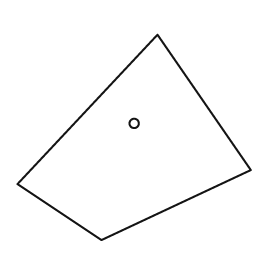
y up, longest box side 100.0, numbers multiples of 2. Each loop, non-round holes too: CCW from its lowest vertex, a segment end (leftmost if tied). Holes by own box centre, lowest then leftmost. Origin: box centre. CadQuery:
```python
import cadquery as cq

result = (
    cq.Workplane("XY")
    .moveTo(-14.0, -44.0)
    .lineTo(50.0, -14.0)
    .lineTo(10.0, 44.0)
    .lineTo(-50.0, -20.0)
    .close()
    .moveTo(0.0, 6.0)
    .circle(2.0)
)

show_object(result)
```